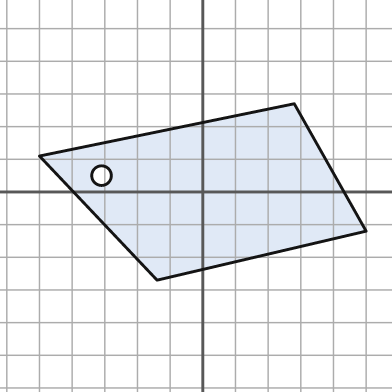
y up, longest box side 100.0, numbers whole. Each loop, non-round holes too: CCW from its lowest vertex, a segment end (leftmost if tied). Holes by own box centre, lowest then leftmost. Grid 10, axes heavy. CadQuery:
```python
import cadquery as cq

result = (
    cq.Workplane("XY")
    .moveTo(-14.0, -27.0)
    .lineTo(50.0, -12.0)
    .lineTo(28.0, 27.0)
    .lineTo(-50.0, 11.0)
    .close()
    .moveTo(-31.0, 5.0)
    .circle(3.0)
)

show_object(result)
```